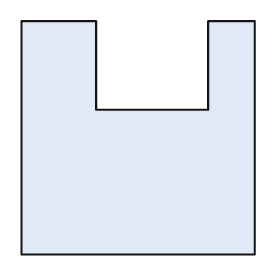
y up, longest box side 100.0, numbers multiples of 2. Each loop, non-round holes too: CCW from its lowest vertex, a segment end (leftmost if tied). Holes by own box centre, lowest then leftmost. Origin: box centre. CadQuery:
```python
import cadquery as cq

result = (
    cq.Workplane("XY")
    .moveTo(-50.0, -50.0)
    .lineTo(50.0, -50.0)
    .lineTo(50.0, 50.0)
    .lineTo(30.0, 50.0)
    .lineTo(30.0, 12.0)
    .lineTo(-18.0, 12.0)
    .lineTo(-18.0, 50.0)
    .lineTo(-50.0, 50.0)
    .close()
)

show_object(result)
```